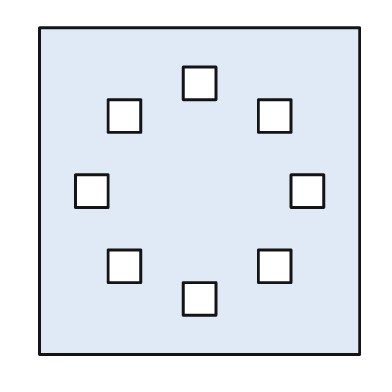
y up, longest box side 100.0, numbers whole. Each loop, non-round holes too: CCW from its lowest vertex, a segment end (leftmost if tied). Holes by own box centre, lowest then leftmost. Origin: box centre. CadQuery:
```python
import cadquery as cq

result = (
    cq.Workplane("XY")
    .moveTo(-49.0, -50.0)
    .lineTo(49.0, -50.0)
    .lineTo(49.0, 50.0)
    .lineTo(-49.0, 50.0)
    .close()
    .moveTo(-5.0, -38.0)
    .lineTo(5.0, -38.0)
    .lineTo(5.0, -28.0)
    .lineTo(-5.0, -28.0)
    .close()
    .moveTo(-28.0, -28.0)
    .lineTo(-18.0, -28.0)
    .lineTo(-18.0, -18.0)
    .lineTo(-28.0, -18.0)
    .close()
    .moveTo(18.0, -28.0)
    .lineTo(28.0, -28.0)
    .lineTo(28.0, -18.0)
    .lineTo(18.0, -18.0)
    .close()
    .moveTo(-38.0, -5.0)
    .lineTo(-28.0, -5.0)
    .lineTo(-28.0, 5.0)
    .lineTo(-38.0, 5.0)
    .close()
    .moveTo(28.0, -5.0)
    .lineTo(38.0, -5.0)
    .lineTo(38.0, 5.0)
    .lineTo(28.0, 5.0)
    .close()
    .moveTo(-28.0, 18.0)
    .lineTo(-18.0, 18.0)
    .lineTo(-18.0, 28.0)
    .lineTo(-28.0, 28.0)
    .close()
    .moveTo(18.0, 18.0)
    .lineTo(28.0, 18.0)
    .lineTo(28.0, 28.0)
    .lineTo(18.0, 28.0)
    .close()
    .moveTo(-5.0, 28.0)
    .lineTo(5.0, 28.0)
    .lineTo(5.0, 38.0)
    .lineTo(-5.0, 38.0)
    .close()
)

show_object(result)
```